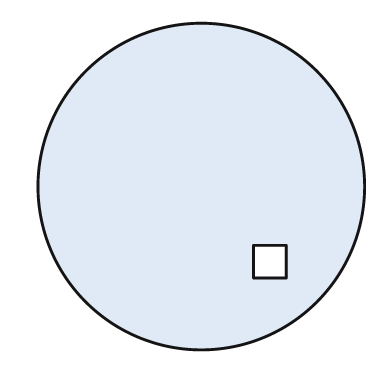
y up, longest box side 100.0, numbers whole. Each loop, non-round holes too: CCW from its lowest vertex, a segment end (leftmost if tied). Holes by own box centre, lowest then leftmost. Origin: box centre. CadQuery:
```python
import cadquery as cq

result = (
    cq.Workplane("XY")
    .moveTo(0.0, 0.0)
    .circle(50.0)
    .moveTo(16.0, -28.0)
    .lineTo(26.0, -28.0)
    .lineTo(26.0, -18.0)
    .lineTo(16.0, -18.0)
    .close()
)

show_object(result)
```